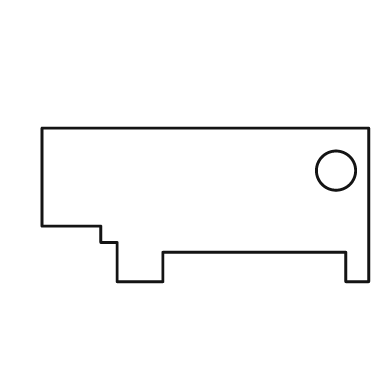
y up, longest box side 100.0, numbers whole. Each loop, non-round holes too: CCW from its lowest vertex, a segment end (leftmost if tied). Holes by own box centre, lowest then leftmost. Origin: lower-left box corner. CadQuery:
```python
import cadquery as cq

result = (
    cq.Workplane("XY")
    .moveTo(23.0, 0.0)
    .lineTo(37.0, 0.0)
    .lineTo(37.0, 9.0)
    .lineTo(93.0, 9.0)
    .lineTo(93.0, 0.0)
    .lineTo(100.0, 0.0)
    .lineTo(100.0, 47.0)
    .lineTo(0.0, 47.0)
    .lineTo(0.0, 17.0)
    .lineTo(18.0, 17.0)
    .lineTo(18.0, 12.0)
    .lineTo(23.0, 12.0)
    .close()
    .moveTo(90.0, 34.0)
    .circle(6.0)
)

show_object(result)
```